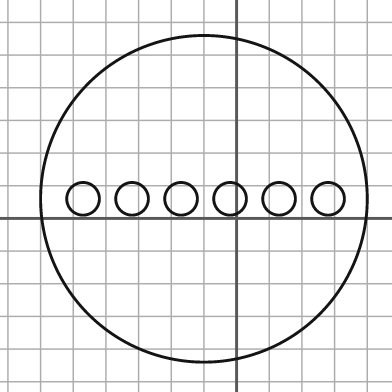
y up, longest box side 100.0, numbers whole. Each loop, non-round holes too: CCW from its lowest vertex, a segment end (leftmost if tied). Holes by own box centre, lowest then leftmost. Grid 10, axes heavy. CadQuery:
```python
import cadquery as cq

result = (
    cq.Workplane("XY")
    .moveTo(-10.0, 6.0)
    .circle(50.0)
    .moveTo(-47.0, 6.0)
    .circle(5.0)
    .moveTo(-32.0, 6.0)
    .circle(5.0)
    .moveTo(-17.0, 6.0)
    .circle(5.0)
    .moveTo(-2.0, 6.0)
    .circle(5.0)
    .moveTo(13.0, 6.0)
    .circle(5.0)
    .moveTo(28.0, 6.0)
    .circle(5.0)
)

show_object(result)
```